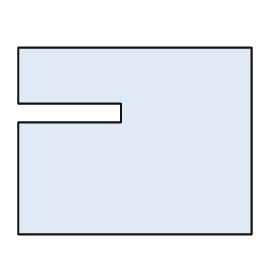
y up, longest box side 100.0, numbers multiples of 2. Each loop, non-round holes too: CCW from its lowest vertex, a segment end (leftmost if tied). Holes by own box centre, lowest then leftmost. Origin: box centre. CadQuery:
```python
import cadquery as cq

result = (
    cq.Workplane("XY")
    .moveTo(-50.0, -40.0)
    .lineTo(50.0, -40.0)
    .lineTo(50.0, 40.0)
    .lineTo(-50.0, 40.0)
    .lineTo(-50.0, 16.0)
    .lineTo(-6.0, 16.0)
    .lineTo(-6.0, 8.0)
    .lineTo(-50.0, 8.0)
    .close()
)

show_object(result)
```